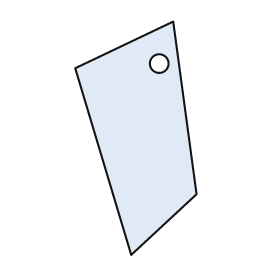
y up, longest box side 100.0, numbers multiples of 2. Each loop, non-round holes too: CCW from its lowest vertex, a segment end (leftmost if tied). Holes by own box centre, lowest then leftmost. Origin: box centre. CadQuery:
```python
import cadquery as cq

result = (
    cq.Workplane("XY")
    .moveTo(-2.0, -50.0)
    .lineTo(26.0, -24.0)
    .lineTo(16.0, 50.0)
    .lineTo(-26.0, 30.0)
    .close()
    .moveTo(10.0, 32.0)
    .circle(4.0)
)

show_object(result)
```